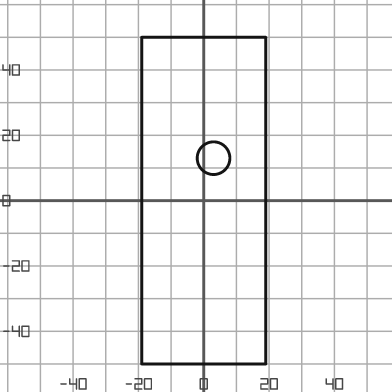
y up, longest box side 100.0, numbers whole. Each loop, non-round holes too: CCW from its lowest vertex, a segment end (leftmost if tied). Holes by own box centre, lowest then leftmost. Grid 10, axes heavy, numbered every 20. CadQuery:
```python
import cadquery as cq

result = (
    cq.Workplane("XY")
    .moveTo(-19.0, -50.0)
    .lineTo(19.0, -50.0)
    .lineTo(19.0, 50.0)
    .lineTo(-19.0, 50.0)
    .close()
    .moveTo(3.0, 13.0)
    .circle(5.0)
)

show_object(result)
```